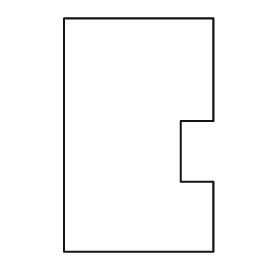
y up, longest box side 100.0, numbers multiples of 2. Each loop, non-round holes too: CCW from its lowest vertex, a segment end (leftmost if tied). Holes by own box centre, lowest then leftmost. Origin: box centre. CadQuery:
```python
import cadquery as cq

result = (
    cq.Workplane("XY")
    .moveTo(-32.0, -50.0)
    .lineTo(32.0, -50.0)
    .lineTo(32.0, -20.0)
    .lineTo(18.0, -20.0)
    .lineTo(18.0, 6.0)
    .lineTo(32.0, 6.0)
    .lineTo(32.0, 50.0)
    .lineTo(-32.0, 50.0)
    .close()
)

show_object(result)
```